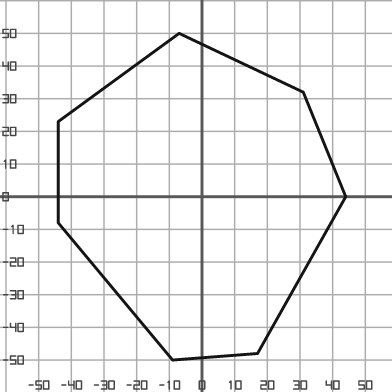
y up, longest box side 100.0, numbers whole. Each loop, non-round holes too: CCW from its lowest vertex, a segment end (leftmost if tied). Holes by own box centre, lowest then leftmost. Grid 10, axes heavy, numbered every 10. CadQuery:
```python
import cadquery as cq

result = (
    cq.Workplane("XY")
    .moveTo(-9.0, -50.0)
    .lineTo(17.0, -48.0)
    .lineTo(44.0, 0.0)
    .lineTo(31.0, 32.0)
    .lineTo(-7.0, 50.0)
    .lineTo(-44.0, 23.0)
    .lineTo(-44.0, -8.0)
    .close()
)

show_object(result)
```